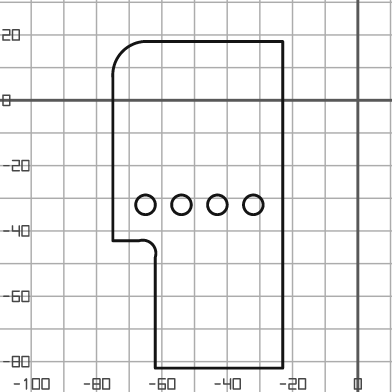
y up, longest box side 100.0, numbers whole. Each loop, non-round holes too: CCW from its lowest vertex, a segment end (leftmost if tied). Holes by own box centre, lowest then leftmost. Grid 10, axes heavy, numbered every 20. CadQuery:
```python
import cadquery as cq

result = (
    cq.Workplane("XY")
    .moveTo(-62.0, -82.0)
    .lineTo(-23.0, -82.0)
    .lineTo(-23.0, 18.0)
    .lineTo(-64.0, 18.0)
    .threePointArc((-72.0, 15.0), (-75.0, 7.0))
    .lineTo(-75.0, -43.0)
    .lineTo(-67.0, -43.0)
    .threePointArc((-63.0, -44.0), (-62.0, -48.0))
    .close()
    .moveTo(-65.0, -32.0)
    .circle(3.0)
    .moveTo(-54.0, -32.0)
    .circle(3.0)
    .moveTo(-43.0, -32.0)
    .circle(3.0)
    .moveTo(-32.0, -32.0)
    .circle(3.0)
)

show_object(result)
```